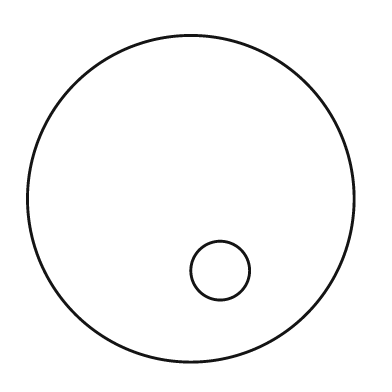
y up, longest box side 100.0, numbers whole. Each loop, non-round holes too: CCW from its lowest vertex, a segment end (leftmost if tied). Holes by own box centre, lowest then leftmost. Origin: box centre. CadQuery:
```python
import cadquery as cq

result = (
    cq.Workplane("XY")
    .moveTo(0.0, 0.0)
    .circle(50.0)
    .moveTo(9.0, -22.0)
    .circle(9.0)
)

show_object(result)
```